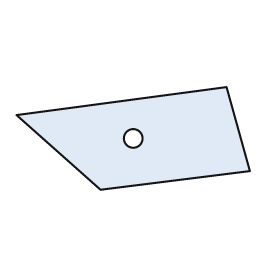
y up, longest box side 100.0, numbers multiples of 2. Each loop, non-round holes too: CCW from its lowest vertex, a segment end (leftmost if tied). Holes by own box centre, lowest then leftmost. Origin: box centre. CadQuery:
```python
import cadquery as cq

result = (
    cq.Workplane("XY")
    .moveTo(-14.0, -22.0)
    .lineTo(50.0, -14.0)
    .lineTo(40.0, 22.0)
    .lineTo(-50.0, 10.0)
    .close()
    .moveTo(0.0, 0.0)
    .circle(4.0)
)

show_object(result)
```